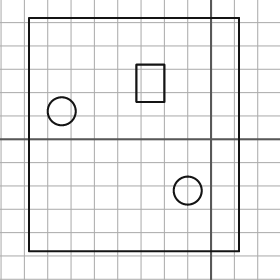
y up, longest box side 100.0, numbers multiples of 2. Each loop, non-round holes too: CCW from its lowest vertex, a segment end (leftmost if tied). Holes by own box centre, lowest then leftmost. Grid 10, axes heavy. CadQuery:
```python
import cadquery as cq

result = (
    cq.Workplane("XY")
    .moveTo(-78.0, -48.0)
    .lineTo(12.0, -48.0)
    .lineTo(12.0, 52.0)
    .lineTo(-78.0, 52.0)
    .close()
    .moveTo(-10.0, -22.0)
    .circle(6.0)
    .moveTo(-64.0, 12.0)
    .circle(6.0)
    .moveTo(-32.0, 16.0)
    .lineTo(-20.0, 16.0)
    .lineTo(-20.0, 32.0)
    .lineTo(-32.0, 32.0)
    .close()
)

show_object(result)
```